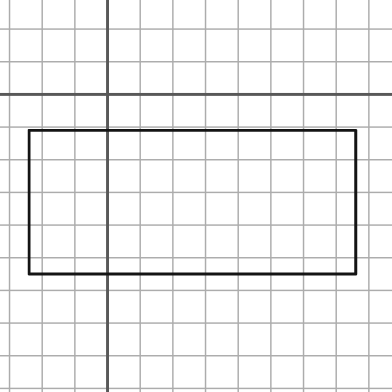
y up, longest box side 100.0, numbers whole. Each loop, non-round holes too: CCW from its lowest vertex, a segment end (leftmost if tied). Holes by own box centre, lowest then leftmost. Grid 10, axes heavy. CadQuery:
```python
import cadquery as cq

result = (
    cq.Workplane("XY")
    .moveTo(-24.0, -55.0)
    .lineTo(76.0, -55.0)
    .lineTo(76.0, -11.0)
    .lineTo(-24.0, -11.0)
    .close()
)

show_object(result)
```